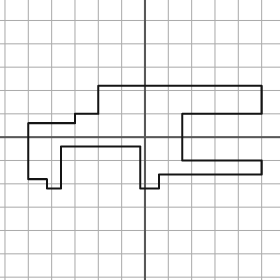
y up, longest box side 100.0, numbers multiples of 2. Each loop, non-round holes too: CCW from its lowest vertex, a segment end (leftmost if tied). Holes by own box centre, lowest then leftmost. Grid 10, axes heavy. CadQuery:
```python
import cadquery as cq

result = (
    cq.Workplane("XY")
    .moveTo(-42.0, -22.0)
    .lineTo(-36.0, -22.0)
    .lineTo(-36.0, -4.0)
    .lineTo(-2.0, -4.0)
    .lineTo(-2.0, -22.0)
    .lineTo(6.0, -22.0)
    .lineTo(6.0, -16.0)
    .lineTo(50.0, -16.0)
    .lineTo(50.0, -10.0)
    .lineTo(16.0, -10.0)
    .lineTo(16.0, 10.0)
    .lineTo(50.0, 10.0)
    .lineTo(50.0, 22.0)
    .lineTo(-20.0, 22.0)
    .lineTo(-20.0, 10.0)
    .lineTo(-30.0, 10.0)
    .lineTo(-30.0, 6.0)
    .lineTo(-50.0, 6.0)
    .lineTo(-50.0, -18.0)
    .lineTo(-42.0, -18.0)
    .close()
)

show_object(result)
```